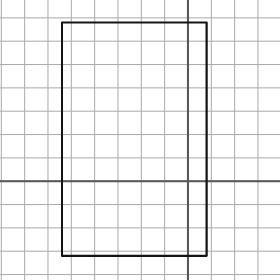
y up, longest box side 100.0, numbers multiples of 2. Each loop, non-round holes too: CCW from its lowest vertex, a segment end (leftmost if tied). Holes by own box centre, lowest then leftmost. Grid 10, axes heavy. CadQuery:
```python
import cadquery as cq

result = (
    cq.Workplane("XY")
    .moveTo(-54.0, -32.0)
    .lineTo(8.0, -32.0)
    .lineTo(8.0, 68.0)
    .lineTo(-54.0, 68.0)
    .close()
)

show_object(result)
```